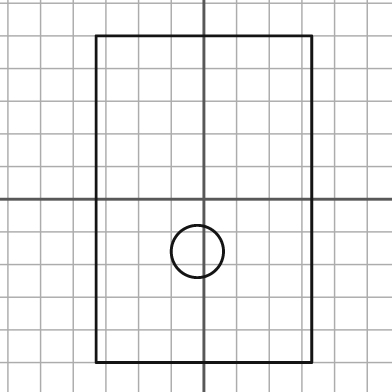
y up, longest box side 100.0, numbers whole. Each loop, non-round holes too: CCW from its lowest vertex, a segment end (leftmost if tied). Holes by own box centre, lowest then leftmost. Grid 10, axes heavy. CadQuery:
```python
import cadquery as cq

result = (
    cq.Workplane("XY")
    .moveTo(-33.0, -50.0)
    .lineTo(33.0, -50.0)
    .lineTo(33.0, 50.0)
    .lineTo(-33.0, 50.0)
    .close()
    .moveTo(-2.0, -16.0)
    .circle(8.0)
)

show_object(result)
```